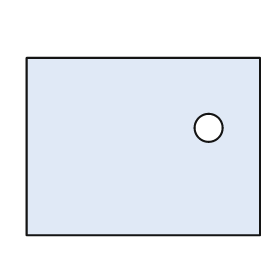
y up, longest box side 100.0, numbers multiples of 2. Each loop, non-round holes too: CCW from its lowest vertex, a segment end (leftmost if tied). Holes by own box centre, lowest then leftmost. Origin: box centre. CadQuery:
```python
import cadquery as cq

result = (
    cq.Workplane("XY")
    .moveTo(-50.0, -38.0)
    .lineTo(50.0, -38.0)
    .lineTo(50.0, 38.0)
    .lineTo(-50.0, 38.0)
    .close()
    .moveTo(28.0, 8.0)
    .circle(6.0)
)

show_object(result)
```